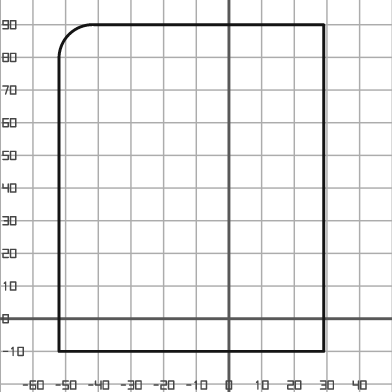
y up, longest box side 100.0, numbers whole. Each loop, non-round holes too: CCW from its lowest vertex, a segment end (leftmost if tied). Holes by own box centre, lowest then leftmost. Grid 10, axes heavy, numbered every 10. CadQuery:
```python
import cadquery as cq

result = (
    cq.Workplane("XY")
    .moveTo(-52.0, -10.0)
    .lineTo(29.0, -10.0)
    .lineTo(29.0, 90.0)
    .lineTo(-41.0, 90.0)
    .threePointArc((-49.0, 87.0), (-52.0, 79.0))
    .close()
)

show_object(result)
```